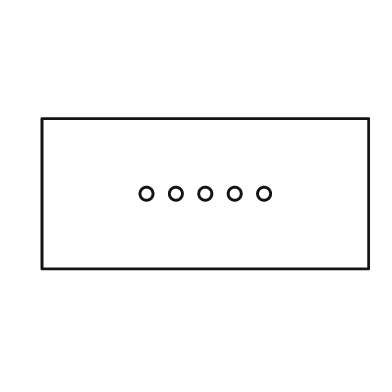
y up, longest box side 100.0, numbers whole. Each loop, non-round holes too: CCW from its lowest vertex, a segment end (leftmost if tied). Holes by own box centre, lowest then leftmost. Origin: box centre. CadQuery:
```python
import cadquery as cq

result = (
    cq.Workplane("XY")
    .moveTo(-50.0, -23.0)
    .lineTo(50.0, -23.0)
    .lineTo(50.0, 23.0)
    .lineTo(-50.0, 23.0)
    .close()
    .moveTo(-18.0, 0.0)
    .circle(2.0)
    .moveTo(-9.0, 0.0)
    .circle(2.0)
    .moveTo(0.0, 0.0)
    .circle(2.0)
    .moveTo(9.0, 0.0)
    .circle(2.0)
    .moveTo(18.0, 0.0)
    .circle(2.0)
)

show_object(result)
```